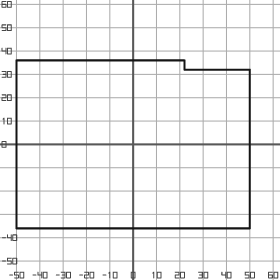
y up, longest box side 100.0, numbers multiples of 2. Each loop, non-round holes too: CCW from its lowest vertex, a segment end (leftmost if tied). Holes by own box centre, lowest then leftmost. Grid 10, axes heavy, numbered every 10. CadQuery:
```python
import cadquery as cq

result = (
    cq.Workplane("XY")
    .moveTo(-50.0, -36.0)
    .lineTo(50.0, -36.0)
    .lineTo(50.0, 32.0)
    .lineTo(22.0, 32.0)
    .lineTo(22.0, 36.0)
    .lineTo(-50.0, 36.0)
    .close()
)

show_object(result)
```